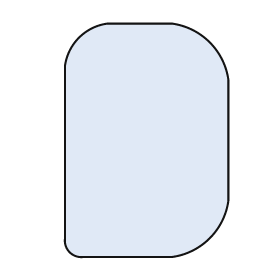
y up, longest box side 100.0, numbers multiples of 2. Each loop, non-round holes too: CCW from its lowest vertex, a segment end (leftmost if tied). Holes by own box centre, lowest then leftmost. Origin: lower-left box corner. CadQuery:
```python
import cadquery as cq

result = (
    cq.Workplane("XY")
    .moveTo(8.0, 0.0)
    .lineTo(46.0, 0.0)
    .threePointArc((62.0, 8.0), (70.0, 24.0))
    .lineTo(70.0, 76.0)
    .threePointArc((62.0, 92.0), (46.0, 100.0))
    .lineTo(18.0, 100.0)
    .threePointArc((6.0, 94.0), (0.0, 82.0))
    .lineTo(0.0, 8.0)
    .threePointArc((2.0, 2.0), (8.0, 0.0))
    .close()
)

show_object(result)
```